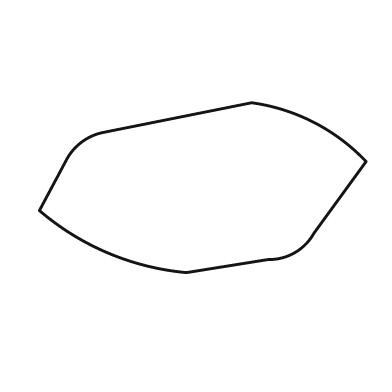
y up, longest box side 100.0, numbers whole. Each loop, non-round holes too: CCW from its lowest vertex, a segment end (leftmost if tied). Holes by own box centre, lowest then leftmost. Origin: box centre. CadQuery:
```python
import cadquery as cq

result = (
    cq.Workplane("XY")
    .moveTo(-5.0, -26.0)
    .lineTo(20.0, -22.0)
    .threePointArc((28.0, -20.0), (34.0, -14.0))
    .lineTo(50.0, 8.0)
    .threePointArc((34.0, 20.0), (15.0, 26.0))
    .lineTo(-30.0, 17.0)
    .threePointArc((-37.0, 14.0), (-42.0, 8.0))
    .lineTo(-50.0, -7.0)
    .threePointArc((-29.0, -20.0), (-5.0, -26.0))
    .close()
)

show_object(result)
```